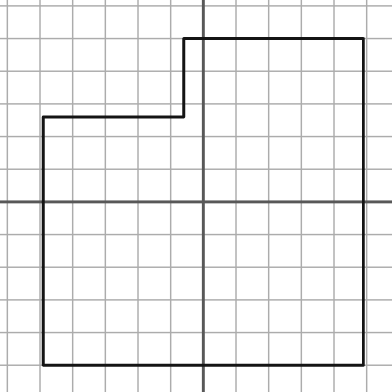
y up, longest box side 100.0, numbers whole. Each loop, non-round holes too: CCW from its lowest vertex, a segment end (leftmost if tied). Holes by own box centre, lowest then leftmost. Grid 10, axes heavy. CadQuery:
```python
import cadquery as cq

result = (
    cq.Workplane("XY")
    .moveTo(-49.0, -50.0)
    .lineTo(49.0, -50.0)
    .lineTo(49.0, 50.0)
    .lineTo(-6.0, 50.0)
    .lineTo(-6.0, 26.0)
    .lineTo(-49.0, 26.0)
    .close()
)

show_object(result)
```